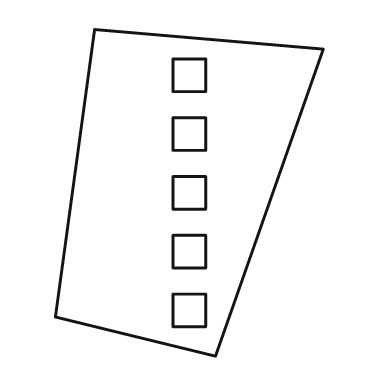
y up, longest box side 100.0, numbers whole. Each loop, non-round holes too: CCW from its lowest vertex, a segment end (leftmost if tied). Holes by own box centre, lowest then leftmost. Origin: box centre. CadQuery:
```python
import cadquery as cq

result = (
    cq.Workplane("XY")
    .moveTo(8.0, -50.0)
    .lineTo(41.0, 44.0)
    .lineTo(-29.0, 50.0)
    .lineTo(-41.0, -38.0)
    .close()
    .moveTo(-5.0, -41.0)
    .lineTo(5.0, -41.0)
    .lineTo(5.0, -31.0)
    .lineTo(-5.0, -31.0)
    .close()
    .moveTo(-5.0, -23.0)
    .lineTo(5.0, -23.0)
    .lineTo(5.0, -13.0)
    .lineTo(-5.0, -13.0)
    .close()
    .moveTo(-5.0, -5.0)
    .lineTo(5.0, -5.0)
    .lineTo(5.0, 5.0)
    .lineTo(-5.0, 5.0)
    .close()
    .moveTo(-5.0, 13.0)
    .lineTo(5.0, 13.0)
    .lineTo(5.0, 23.0)
    .lineTo(-5.0, 23.0)
    .close()
    .moveTo(-5.0, 31.0)
    .lineTo(5.0, 31.0)
    .lineTo(5.0, 41.0)
    .lineTo(-5.0, 41.0)
    .close()
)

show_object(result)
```